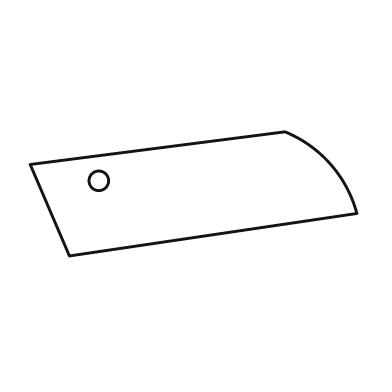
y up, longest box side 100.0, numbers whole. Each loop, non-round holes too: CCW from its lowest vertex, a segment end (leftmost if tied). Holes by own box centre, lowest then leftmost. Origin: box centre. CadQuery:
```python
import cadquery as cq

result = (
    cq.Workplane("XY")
    .moveTo(-38.0, -19.0)
    .lineTo(50.0, -6.0)
    .threePointArc((42.0, 9.0), (28.0, 19.0))
    .lineTo(-50.0, 9.0)
    .close()
    .moveTo(-29.0, 4.0)
    .circle(3.0)
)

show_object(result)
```